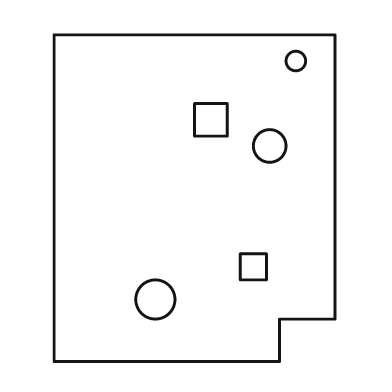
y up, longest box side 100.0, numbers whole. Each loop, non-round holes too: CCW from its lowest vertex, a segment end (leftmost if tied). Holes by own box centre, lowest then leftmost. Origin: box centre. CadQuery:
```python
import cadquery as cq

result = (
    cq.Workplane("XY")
    .moveTo(-43.0, -50.0)
    .lineTo(26.0, -50.0)
    .lineTo(26.0, -37.0)
    .lineTo(43.0, -37.0)
    .lineTo(43.0, 50.0)
    .lineTo(-43.0, 50.0)
    .close()
    .moveTo(-12.0, -31.0)
    .circle(6.0)
    .moveTo(14.0, -25.0)
    .lineTo(22.0, -25.0)
    .lineTo(22.0, -17.0)
    .lineTo(14.0, -17.0)
    .close()
    .moveTo(23.0, 16.0)
    .circle(5.0)
    .moveTo(0.0, 19.0)
    .lineTo(10.0, 19.0)
    .lineTo(10.0, 29.0)
    .lineTo(0.0, 29.0)
    .close()
    .moveTo(31.0, 42.0)
    .circle(3.0)
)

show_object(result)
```